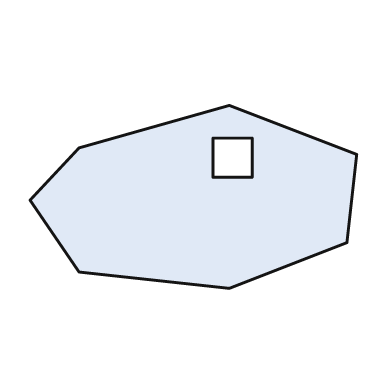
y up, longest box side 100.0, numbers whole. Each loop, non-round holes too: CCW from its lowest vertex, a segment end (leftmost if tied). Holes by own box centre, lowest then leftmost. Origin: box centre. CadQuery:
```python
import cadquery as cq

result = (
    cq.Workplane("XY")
    .moveTo(11.0, -28.0)
    .lineTo(47.0, -14.0)
    .lineTo(50.0, 13.0)
    .lineTo(11.0, 28.0)
    .lineTo(-35.0, 15.0)
    .lineTo(-50.0, -1.0)
    .lineTo(-35.0, -23.0)
    .close()
    .moveTo(6.0, 6.0)
    .lineTo(18.0, 6.0)
    .lineTo(18.0, 18.0)
    .lineTo(6.0, 18.0)
    .close()
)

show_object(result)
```